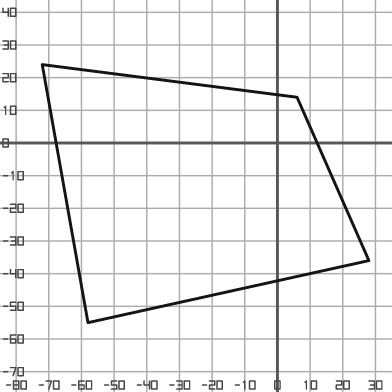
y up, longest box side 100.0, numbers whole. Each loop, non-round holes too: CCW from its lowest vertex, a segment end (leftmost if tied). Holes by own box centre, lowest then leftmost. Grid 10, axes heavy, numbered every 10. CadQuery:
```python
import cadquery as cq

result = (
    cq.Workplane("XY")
    .moveTo(-58.0, -55.0)
    .lineTo(28.0, -36.0)
    .lineTo(6.0, 14.0)
    .lineTo(-72.0, 24.0)
    .close()
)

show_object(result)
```